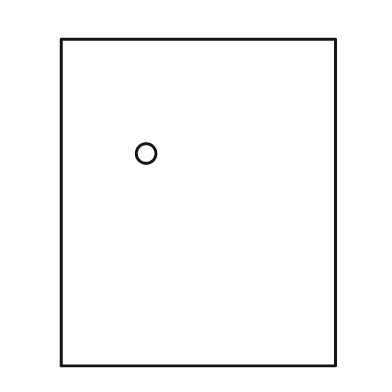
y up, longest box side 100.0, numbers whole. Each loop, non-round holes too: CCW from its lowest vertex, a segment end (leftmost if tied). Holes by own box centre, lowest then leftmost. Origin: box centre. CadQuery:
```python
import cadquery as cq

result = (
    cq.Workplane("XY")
    .moveTo(-42.0, -50.0)
    .lineTo(42.0, -50.0)
    .lineTo(42.0, 50.0)
    .lineTo(-42.0, 50.0)
    .close()
    .moveTo(-16.0, 15.0)
    .circle(3.0)
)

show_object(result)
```